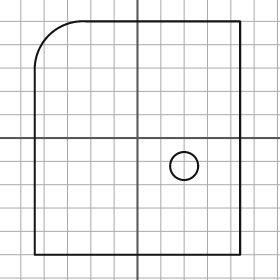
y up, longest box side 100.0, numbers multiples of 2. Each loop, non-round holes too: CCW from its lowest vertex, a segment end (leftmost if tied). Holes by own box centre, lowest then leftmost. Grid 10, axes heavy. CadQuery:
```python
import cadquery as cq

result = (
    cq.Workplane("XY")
    .moveTo(-44.0, -50.0)
    .lineTo(44.0, -50.0)
    .lineTo(44.0, 50.0)
    .lineTo(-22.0, 50.0)
    .threePointArc((-38.0, 44.0), (-44.0, 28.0))
    .close()
    .moveTo(20.0, -12.0)
    .circle(6.0)
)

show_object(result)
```